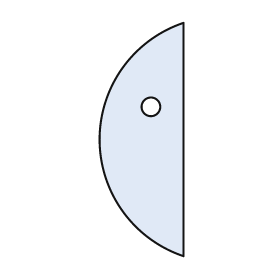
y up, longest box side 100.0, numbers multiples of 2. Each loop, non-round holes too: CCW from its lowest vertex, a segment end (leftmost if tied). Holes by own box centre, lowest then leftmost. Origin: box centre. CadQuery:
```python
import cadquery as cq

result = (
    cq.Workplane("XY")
    .moveTo(18.0, -50.0)
    .lineTo(18.0, 50.0)
    .threePointArc((-18.0, 0.0), (18.0, -50.0))
    .close()
    .moveTo(4.0, 14.0)
    .circle(4.0)
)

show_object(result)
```